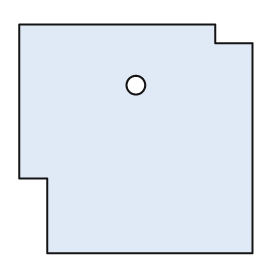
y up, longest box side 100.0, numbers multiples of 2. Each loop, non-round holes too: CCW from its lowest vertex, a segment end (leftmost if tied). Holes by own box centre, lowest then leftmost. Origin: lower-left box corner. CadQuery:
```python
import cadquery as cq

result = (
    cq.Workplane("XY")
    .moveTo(12.0, 0.0)
    .lineTo(100.0, 0.0)
    .lineTo(100.0, 90.0)
    .lineTo(84.0, 90.0)
    .lineTo(84.0, 98.0)
    .lineTo(0.0, 98.0)
    .lineTo(0.0, 32.0)
    .lineTo(12.0, 32.0)
    .close()
    .moveTo(50.0, 72.0)
    .circle(4.0)
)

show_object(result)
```